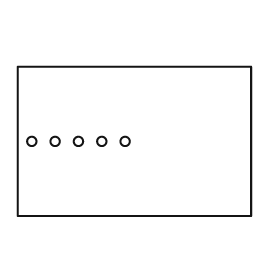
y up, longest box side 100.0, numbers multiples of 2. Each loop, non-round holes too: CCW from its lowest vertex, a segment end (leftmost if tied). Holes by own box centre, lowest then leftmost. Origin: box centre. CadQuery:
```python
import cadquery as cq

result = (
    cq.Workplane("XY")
    .moveTo(-50.0, -32.0)
    .lineTo(50.0, -32.0)
    .lineTo(50.0, 32.0)
    .lineTo(-50.0, 32.0)
    .close()
    .moveTo(-44.0, 0.0)
    .circle(2.0)
    .moveTo(-34.0, 0.0)
    .circle(2.0)
    .moveTo(-24.0, 0.0)
    .circle(2.0)
    .moveTo(-14.0, 0.0)
    .circle(2.0)
    .moveTo(-4.0, 0.0)
    .circle(2.0)
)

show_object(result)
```